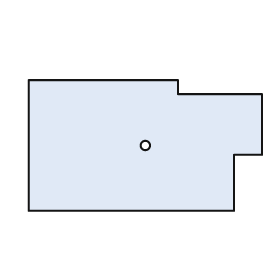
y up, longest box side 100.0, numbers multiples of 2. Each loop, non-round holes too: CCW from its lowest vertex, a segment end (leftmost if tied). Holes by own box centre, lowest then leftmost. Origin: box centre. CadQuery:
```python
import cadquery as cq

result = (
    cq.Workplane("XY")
    .moveTo(-50.0, -28.0)
    .lineTo(38.0, -28.0)
    .lineTo(38.0, -4.0)
    .lineTo(50.0, -4.0)
    .lineTo(50.0, 22.0)
    .lineTo(14.0, 22.0)
    .lineTo(14.0, 28.0)
    .lineTo(-50.0, 28.0)
    .close()
    .moveTo(0.0, 0.0)
    .circle(2.0)
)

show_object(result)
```